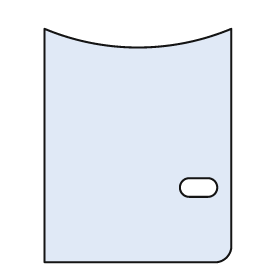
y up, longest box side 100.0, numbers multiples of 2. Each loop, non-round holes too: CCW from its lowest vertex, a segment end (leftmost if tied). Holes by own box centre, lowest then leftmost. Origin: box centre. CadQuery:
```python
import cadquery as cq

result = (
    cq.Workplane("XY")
    .moveTo(-40.0, -50.0)
    .lineTo(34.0, -50.0)
    .threePointArc((38.0, -48.0), (40.0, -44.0))
    .lineTo(40.0, 50.0)
    .threePointArc((0.0, 42.0), (-40.0, 50.0))
    .close()
    .moveTo(22.0, -22.0)
    .lineTo(30.0, -22.0)
    .threePointArc((34.0, -18.0), (30.0, -14.0))
    .lineTo(22.0, -14.0)
    .threePointArc((18.0, -18.0), (22.0, -22.0))
    .close()
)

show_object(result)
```